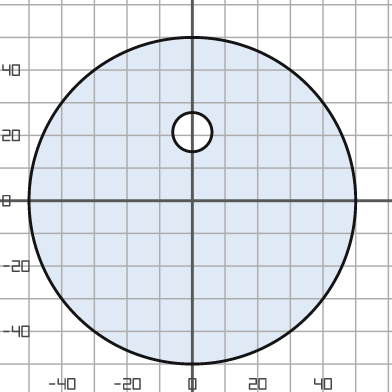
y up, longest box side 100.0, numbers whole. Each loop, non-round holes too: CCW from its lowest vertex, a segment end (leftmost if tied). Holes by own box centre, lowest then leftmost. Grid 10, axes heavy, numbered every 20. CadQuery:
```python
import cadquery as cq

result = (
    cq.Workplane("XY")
    .moveTo(0.0, 0.0)
    .circle(50.0)
    .moveTo(0.0, 21.0)
    .circle(6.0)
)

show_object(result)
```